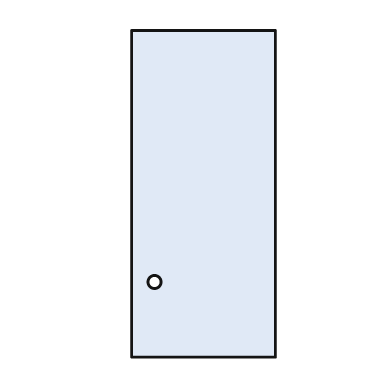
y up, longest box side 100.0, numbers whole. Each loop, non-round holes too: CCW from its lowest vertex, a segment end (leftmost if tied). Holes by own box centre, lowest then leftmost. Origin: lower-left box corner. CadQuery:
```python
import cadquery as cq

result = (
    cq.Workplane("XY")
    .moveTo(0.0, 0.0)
    .lineTo(44.0, 0.0)
    .lineTo(44.0, 100.0)
    .lineTo(0.0, 100.0)
    .close()
    .moveTo(7.0, 23.0)
    .circle(2.0)
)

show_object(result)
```